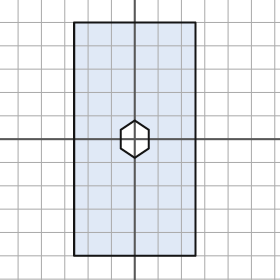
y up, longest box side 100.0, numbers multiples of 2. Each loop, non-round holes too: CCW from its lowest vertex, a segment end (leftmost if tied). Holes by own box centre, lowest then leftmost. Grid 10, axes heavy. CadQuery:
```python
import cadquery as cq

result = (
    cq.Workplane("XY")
    .moveTo(-26.0, -50.0)
    .lineTo(26.0, -50.0)
    .lineTo(26.0, 50.0)
    .lineTo(-26.0, 50.0)
    .close()
    .moveTo(0.0, -8.0)
    .lineTo(6.0, -4.0)
    .lineTo(6.0, 4.0)
    .lineTo(0.0, 8.0)
    .lineTo(-6.0, 4.0)
    .lineTo(-6.0, -4.0)
    .close()
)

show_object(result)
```